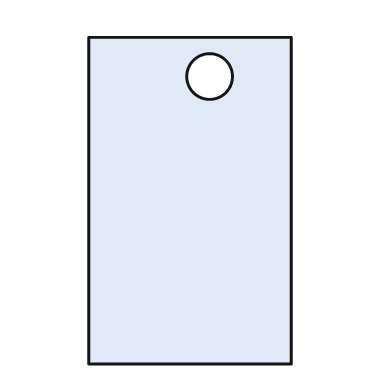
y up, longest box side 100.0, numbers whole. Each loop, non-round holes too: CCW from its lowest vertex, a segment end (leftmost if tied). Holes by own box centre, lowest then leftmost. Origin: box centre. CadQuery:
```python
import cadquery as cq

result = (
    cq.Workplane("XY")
    .moveTo(-31.0, -50.0)
    .lineTo(31.0, -50.0)
    .lineTo(31.0, 50.0)
    .lineTo(-31.0, 50.0)
    .close()
    .moveTo(6.0, 38.0)
    .circle(7.0)
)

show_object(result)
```